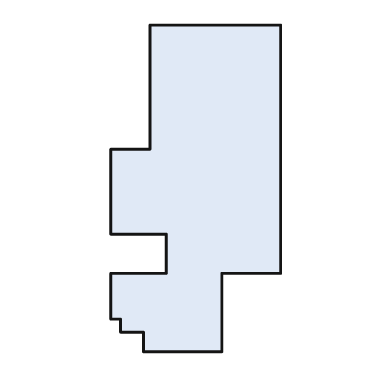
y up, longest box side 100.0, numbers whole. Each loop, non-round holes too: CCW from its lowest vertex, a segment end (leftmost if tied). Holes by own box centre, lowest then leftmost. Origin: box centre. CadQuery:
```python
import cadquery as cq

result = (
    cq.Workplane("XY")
    .moveTo(-16.0, -50.0)
    .lineTo(8.0, -50.0)
    .lineTo(8.0, -26.0)
    .lineTo(26.0, -26.0)
    .lineTo(26.0, 50.0)
    .lineTo(-14.0, 50.0)
    .lineTo(-14.0, 12.0)
    .lineTo(-26.0, 12.0)
    .lineTo(-26.0, -14.0)
    .lineTo(-9.0, -14.0)
    .lineTo(-9.0, -26.0)
    .lineTo(-26.0, -26.0)
    .lineTo(-26.0, -40.0)
    .lineTo(-23.0, -40.0)
    .lineTo(-23.0, -44.0)
    .lineTo(-16.0, -44.0)
    .close()
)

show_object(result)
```